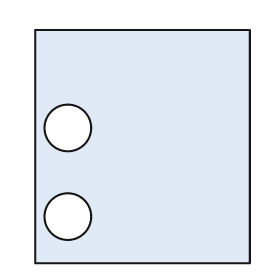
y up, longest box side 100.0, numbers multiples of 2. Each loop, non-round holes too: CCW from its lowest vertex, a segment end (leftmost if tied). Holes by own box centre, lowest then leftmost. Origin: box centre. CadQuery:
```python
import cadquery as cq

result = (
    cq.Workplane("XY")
    .moveTo(-46.0, -50.0)
    .lineTo(46.0, -50.0)
    .lineTo(46.0, 50.0)
    .lineTo(-46.0, 50.0)
    .close()
    .moveTo(-32.0, -30.0)
    .circle(10.0)
    .moveTo(-32.0, 8.0)
    .circle(10.0)
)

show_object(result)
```